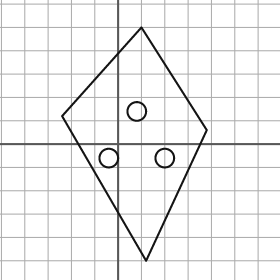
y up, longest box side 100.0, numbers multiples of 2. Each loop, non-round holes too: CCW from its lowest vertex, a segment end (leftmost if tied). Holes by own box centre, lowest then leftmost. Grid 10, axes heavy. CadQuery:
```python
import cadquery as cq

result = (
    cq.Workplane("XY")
    .moveTo(12.0, -50.0)
    .lineTo(38.0, 6.0)
    .lineTo(10.0, 50.0)
    .lineTo(-24.0, 12.0)
    .close()
    .moveTo(-4.0, -6.0)
    .circle(4.0)
    .moveTo(20.0, -6.0)
    .circle(4.0)
    .moveTo(8.0, 14.0)
    .circle(4.0)
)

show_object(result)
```